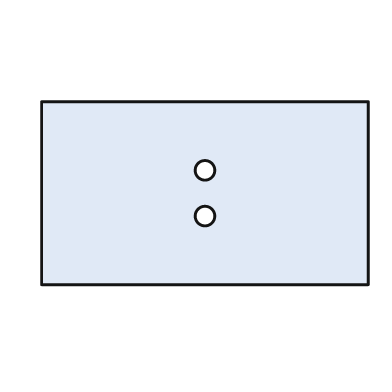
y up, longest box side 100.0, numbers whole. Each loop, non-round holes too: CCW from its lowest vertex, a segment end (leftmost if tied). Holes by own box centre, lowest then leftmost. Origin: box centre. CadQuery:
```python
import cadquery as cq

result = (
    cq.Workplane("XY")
    .moveTo(-50.0, -28.0)
    .lineTo(50.0, -28.0)
    .lineTo(50.0, 28.0)
    .lineTo(-50.0, 28.0)
    .close()
    .moveTo(0.0, -7.0)
    .circle(3.0)
    .moveTo(0.0, 7.0)
    .circle(3.0)
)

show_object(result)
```